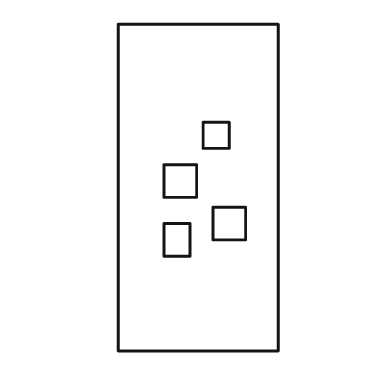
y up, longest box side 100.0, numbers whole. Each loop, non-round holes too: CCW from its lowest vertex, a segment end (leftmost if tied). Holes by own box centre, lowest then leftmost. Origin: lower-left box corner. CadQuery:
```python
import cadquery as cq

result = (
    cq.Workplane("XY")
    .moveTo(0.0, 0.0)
    .lineTo(49.0, 0.0)
    .lineTo(49.0, 100.0)
    .lineTo(0.0, 100.0)
    .close()
    .moveTo(14.0, 29.0)
    .lineTo(22.0, 29.0)
    .lineTo(22.0, 39.0)
    .lineTo(14.0, 39.0)
    .close()
    .moveTo(29.0, 34.0)
    .lineTo(39.0, 34.0)
    .lineTo(39.0, 44.0)
    .lineTo(29.0, 44.0)
    .close()
    .moveTo(14.0, 47.0)
    .lineTo(24.0, 47.0)
    .lineTo(24.0, 57.0)
    .lineTo(14.0, 57.0)
    .close()
    .moveTo(26.0, 62.0)
    .lineTo(34.0, 62.0)
    .lineTo(34.0, 70.0)
    .lineTo(26.0, 70.0)
    .close()
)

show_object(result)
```